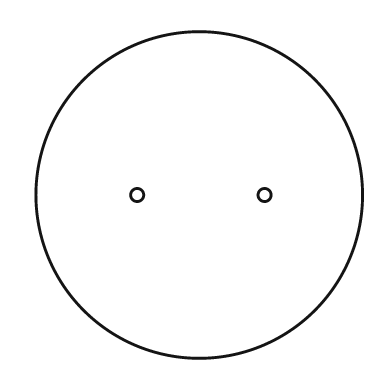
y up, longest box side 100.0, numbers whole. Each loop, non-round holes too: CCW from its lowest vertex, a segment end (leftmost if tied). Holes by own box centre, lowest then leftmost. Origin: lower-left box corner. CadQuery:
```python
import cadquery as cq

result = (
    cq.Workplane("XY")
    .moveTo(50.0, 50.0)
    .circle(50.0)
    .moveTo(31.0, 50.0)
    .circle(2.0)
    .moveTo(70.0, 50.0)
    .circle(2.0)
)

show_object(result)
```